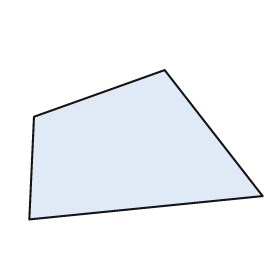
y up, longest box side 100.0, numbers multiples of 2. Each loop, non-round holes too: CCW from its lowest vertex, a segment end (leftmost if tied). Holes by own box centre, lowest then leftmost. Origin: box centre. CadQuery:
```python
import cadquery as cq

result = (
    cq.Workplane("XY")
    .moveTo(-50.0, -32.0)
    .lineTo(50.0, -22.0)
    .lineTo(8.0, 32.0)
    .lineTo(-48.0, 12.0)
    .close()
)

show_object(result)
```